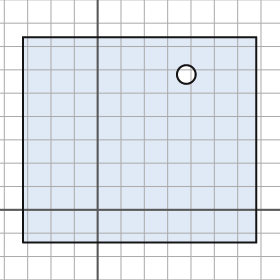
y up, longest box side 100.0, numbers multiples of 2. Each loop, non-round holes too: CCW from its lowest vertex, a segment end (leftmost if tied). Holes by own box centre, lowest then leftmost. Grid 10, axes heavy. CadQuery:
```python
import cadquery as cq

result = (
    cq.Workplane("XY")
    .moveTo(-32.0, -14.0)
    .lineTo(68.0, -14.0)
    .lineTo(68.0, 74.0)
    .lineTo(-32.0, 74.0)
    .close()
    .moveTo(38.0, 58.0)
    .circle(4.0)
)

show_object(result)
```